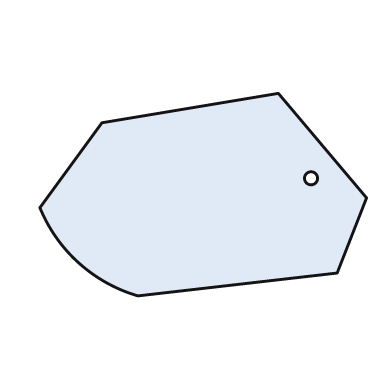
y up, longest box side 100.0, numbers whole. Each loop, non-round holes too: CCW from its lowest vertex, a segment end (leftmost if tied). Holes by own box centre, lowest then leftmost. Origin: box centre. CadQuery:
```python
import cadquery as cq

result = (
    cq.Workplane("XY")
    .moveTo(-20.0, -31.0)
    .lineTo(41.0, -24.0)
    .lineTo(50.0, -1.0)
    .lineTo(23.0, 31.0)
    .lineTo(-31.0, 22.0)
    .lineTo(-50.0, -4.0)
    .threePointArc((-38.0, -21.0), (-20.0, -31.0))
    .close()
    .moveTo(33.0, 5.0)
    .circle(2.0)
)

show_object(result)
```